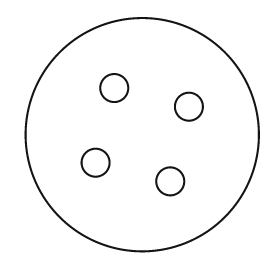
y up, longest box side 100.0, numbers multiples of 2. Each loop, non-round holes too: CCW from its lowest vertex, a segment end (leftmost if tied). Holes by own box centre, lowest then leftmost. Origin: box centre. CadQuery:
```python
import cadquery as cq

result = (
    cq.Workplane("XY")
    .moveTo(0.0, 0.0)
    .circle(50.0)
    .moveTo(12.0, -20.0)
    .circle(6.0)
    .moveTo(-20.0, -12.0)
    .circle(6.0)
    .moveTo(20.0, 12.0)
    .circle(6.0)
    .moveTo(-12.0, 20.0)
    .circle(6.0)
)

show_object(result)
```